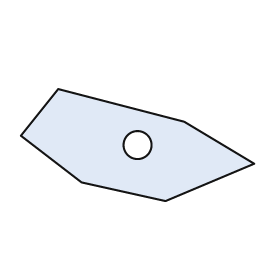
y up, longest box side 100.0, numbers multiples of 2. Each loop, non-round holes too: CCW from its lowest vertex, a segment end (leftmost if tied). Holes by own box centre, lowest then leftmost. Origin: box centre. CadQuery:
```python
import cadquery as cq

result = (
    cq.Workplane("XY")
    .moveTo(12.0, -24.0)
    .lineTo(50.0, -8.0)
    .lineTo(20.0, 10.0)
    .lineTo(-34.0, 24.0)
    .lineTo(-50.0, 4.0)
    .lineTo(-24.0, -16.0)
    .close()
    .moveTo(0.0, 0.0)
    .circle(6.0)
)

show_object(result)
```